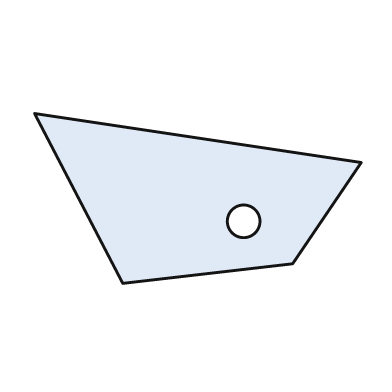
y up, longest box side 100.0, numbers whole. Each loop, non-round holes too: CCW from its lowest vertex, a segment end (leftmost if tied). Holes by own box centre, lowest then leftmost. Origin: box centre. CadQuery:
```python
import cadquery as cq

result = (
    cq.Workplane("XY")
    .moveTo(-23.0, -26.0)
    .lineTo(29.0, -20.0)
    .lineTo(50.0, 11.0)
    .lineTo(-50.0, 26.0)
    .close()
    .moveTo(14.0, -7.0)
    .circle(5.0)
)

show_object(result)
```